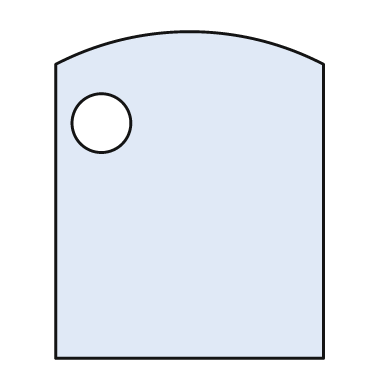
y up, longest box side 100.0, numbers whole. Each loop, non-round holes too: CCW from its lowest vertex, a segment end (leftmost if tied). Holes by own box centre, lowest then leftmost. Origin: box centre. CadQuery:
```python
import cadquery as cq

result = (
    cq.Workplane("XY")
    .moveTo(-41.0, -50.0)
    .lineTo(41.0, -50.0)
    .lineTo(41.0, 40.0)
    .threePointArc((0.0, 50.0), (-41.0, 40.0))
    .close()
    .moveTo(-27.0, 22.0)
    .circle(9.0)
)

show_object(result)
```